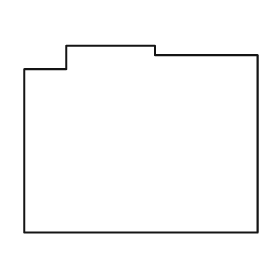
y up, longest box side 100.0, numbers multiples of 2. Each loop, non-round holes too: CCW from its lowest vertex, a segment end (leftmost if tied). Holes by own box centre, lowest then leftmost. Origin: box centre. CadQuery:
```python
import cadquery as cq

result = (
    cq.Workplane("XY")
    .moveTo(-50.0, -40.0)
    .lineTo(50.0, -40.0)
    .lineTo(50.0, 36.0)
    .lineTo(6.0, 36.0)
    .lineTo(6.0, 40.0)
    .lineTo(-32.0, 40.0)
    .lineTo(-32.0, 30.0)
    .lineTo(-50.0, 30.0)
    .close()
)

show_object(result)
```